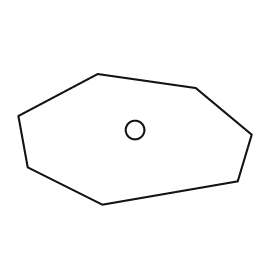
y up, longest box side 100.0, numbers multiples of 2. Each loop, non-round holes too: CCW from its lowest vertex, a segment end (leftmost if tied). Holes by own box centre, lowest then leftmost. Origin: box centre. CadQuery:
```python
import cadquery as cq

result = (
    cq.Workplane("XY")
    .moveTo(-14.0, -28.0)
    .lineTo(44.0, -18.0)
    .lineTo(50.0, 2.0)
    .lineTo(26.0, 22.0)
    .lineTo(-16.0, 28.0)
    .lineTo(-50.0, 10.0)
    .lineTo(-46.0, -12.0)
    .close()
    .moveTo(0.0, 4.0)
    .circle(4.0)
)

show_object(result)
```